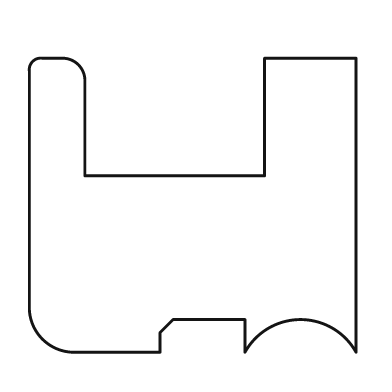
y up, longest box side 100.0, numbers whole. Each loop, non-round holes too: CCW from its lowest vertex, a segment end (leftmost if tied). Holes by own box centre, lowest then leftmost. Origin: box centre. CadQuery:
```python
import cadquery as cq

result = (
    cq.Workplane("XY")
    .moveTo(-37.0, -45.0)
    .lineTo(-10.0, -45.0)
    .lineTo(-10.0, -39.0)
    .lineTo(-6.0, -35.0)
    .lineTo(16.0, -35.0)
    .lineTo(16.0, -45.0)
    .threePointArc((33.0, -35.0), (50.0, -45.0))
    .lineTo(50.0, 45.0)
    .lineTo(22.0, 45.0)
    .lineTo(22.0, 9.0)
    .lineTo(-33.0, 9.0)
    .lineTo(-33.0, 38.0)
    .threePointArc((-35.0, 43.0), (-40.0, 45.0))
    .lineTo(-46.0, 45.0)
    .threePointArc((-49.0, 44.0), (-50.0, 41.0))
    .lineTo(-50.0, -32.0)
    .threePointArc((-46.0, -41.0), (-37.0, -45.0))
    .close()
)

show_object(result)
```